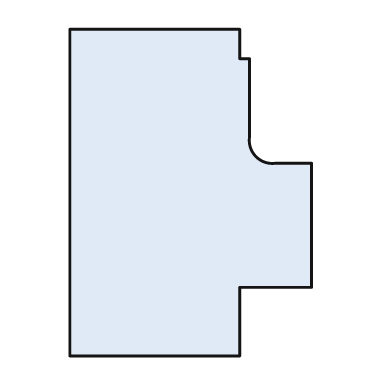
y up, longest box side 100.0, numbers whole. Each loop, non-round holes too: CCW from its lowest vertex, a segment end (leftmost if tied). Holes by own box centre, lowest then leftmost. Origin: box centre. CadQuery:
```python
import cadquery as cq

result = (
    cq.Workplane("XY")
    .moveTo(-37.0, -50.0)
    .lineTo(15.0, -50.0)
    .lineTo(15.0, -29.0)
    .lineTo(37.0, -29.0)
    .lineTo(37.0, 9.0)
    .lineTo(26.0, 9.0)
    .threePointArc((20.0, 11.0), (18.0, 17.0))
    .lineTo(18.0, 41.0)
    .lineTo(15.0, 41.0)
    .lineTo(15.0, 50.0)
    .lineTo(-37.0, 50.0)
    .close()
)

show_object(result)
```